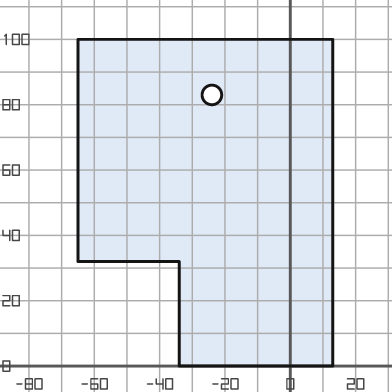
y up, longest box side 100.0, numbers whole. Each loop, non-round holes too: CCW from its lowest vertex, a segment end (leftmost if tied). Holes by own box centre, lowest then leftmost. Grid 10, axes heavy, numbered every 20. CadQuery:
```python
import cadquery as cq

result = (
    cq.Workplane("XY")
    .moveTo(-34.0, 0.0)
    .lineTo(13.0, 0.0)
    .lineTo(13.0, 100.0)
    .lineTo(-65.0, 100.0)
    .lineTo(-65.0, 32.0)
    .lineTo(-34.0, 32.0)
    .close()
    .moveTo(-24.0, 83.0)
    .circle(3.0)
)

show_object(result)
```